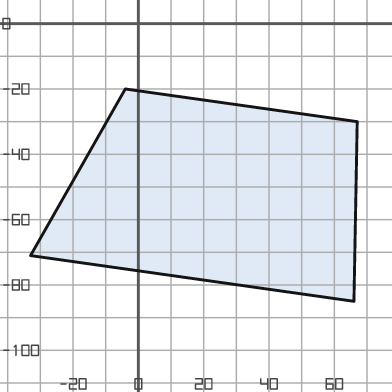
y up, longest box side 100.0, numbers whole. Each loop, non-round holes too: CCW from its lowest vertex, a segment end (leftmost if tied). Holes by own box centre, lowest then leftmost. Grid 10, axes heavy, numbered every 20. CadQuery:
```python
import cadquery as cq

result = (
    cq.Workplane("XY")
    .moveTo(66.0, -85.0)
    .lineTo(67.0, -30.0)
    .lineTo(-4.0, -20.0)
    .lineTo(-33.0, -71.0)
    .close()
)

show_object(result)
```